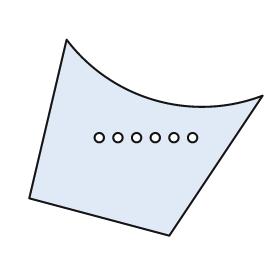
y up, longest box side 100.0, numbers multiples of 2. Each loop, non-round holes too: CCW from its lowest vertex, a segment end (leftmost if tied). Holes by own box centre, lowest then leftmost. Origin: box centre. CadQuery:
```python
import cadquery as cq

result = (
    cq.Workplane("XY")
    .moveTo(10.0, -42.0)
    .lineTo(50.0, 18.0)
    .threePointArc((4.0, 16.0), (-34.0, 42.0))
    .lineTo(-50.0, -26.0)
    .close()
    .moveTo(-20.0, 0.0)
    .circle(2.0)
    .moveTo(-12.0, 0.0)
    .circle(2.0)
    .moveTo(-4.0, 0.0)
    .circle(2.0)
    .moveTo(4.0, 0.0)
    .circle(2.0)
    .moveTo(12.0, 0.0)
    .circle(2.0)
    .moveTo(20.0, 0.0)
    .circle(2.0)
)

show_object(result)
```